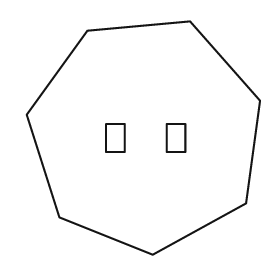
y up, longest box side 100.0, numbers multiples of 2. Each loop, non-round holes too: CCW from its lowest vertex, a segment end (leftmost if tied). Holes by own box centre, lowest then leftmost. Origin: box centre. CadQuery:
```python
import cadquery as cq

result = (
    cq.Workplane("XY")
    .moveTo(4.0, -50.0)
    .lineTo(44.0, -28.0)
    .lineTo(50.0, 16.0)
    .lineTo(20.0, 50.0)
    .lineTo(-24.0, 46.0)
    .lineTo(-50.0, 10.0)
    .lineTo(-36.0, -34.0)
    .close()
    .moveTo(-16.0, -6.0)
    .lineTo(-8.0, -6.0)
    .lineTo(-8.0, 6.0)
    .lineTo(-16.0, 6.0)
    .close()
    .moveTo(10.0, -6.0)
    .lineTo(18.0, -6.0)
    .lineTo(18.0, 6.0)
    .lineTo(10.0, 6.0)
    .close()
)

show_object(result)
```